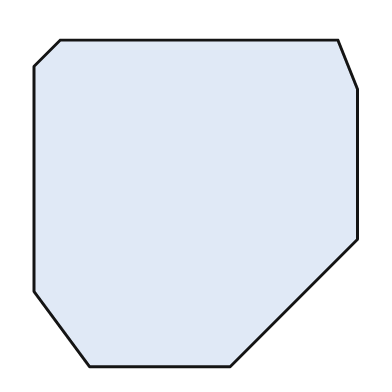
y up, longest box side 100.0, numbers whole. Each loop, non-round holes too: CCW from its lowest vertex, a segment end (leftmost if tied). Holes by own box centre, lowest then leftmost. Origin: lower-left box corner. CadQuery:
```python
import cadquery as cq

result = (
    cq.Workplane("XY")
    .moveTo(17.0, 0.0)
    .lineTo(60.0, 0.0)
    .lineTo(99.0, 39.0)
    .lineTo(99.0, 85.0)
    .lineTo(93.0, 100.0)
    .lineTo(8.0, 100.0)
    .lineTo(0.0, 92.0)
    .lineTo(0.0, 23.0)
    .close()
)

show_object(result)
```